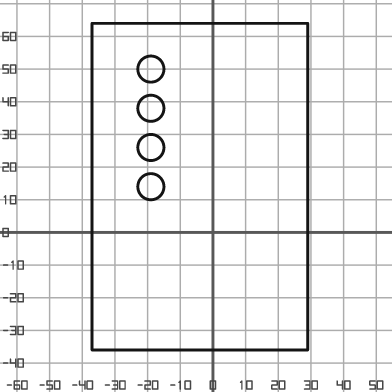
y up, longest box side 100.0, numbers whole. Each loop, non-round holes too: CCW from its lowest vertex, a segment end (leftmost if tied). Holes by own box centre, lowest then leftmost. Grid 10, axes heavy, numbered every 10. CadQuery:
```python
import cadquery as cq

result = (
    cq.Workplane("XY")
    .moveTo(-37.0, -36.0)
    .lineTo(29.0, -36.0)
    .lineTo(29.0, 64.0)
    .lineTo(-37.0, 64.0)
    .close()
    .moveTo(-19.0, 14.0)
    .circle(4.0)
    .moveTo(-19.0, 26.0)
    .circle(4.0)
    .moveTo(-19.0, 38.0)
    .circle(4.0)
    .moveTo(-19.0, 50.0)
    .circle(4.0)
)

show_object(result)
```